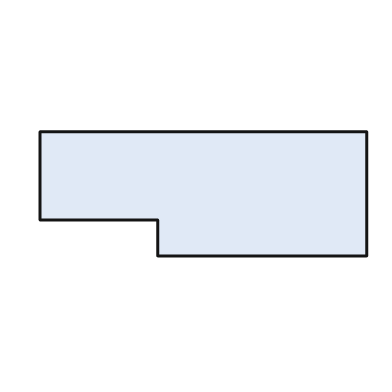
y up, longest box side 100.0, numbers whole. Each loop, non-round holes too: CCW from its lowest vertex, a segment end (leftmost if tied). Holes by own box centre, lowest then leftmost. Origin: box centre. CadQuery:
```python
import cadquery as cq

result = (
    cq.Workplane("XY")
    .moveTo(-14.0, -19.0)
    .lineTo(50.0, -19.0)
    .lineTo(50.0, 19.0)
    .lineTo(-50.0, 19.0)
    .lineTo(-50.0, -8.0)
    .lineTo(-14.0, -8.0)
    .close()
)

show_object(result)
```